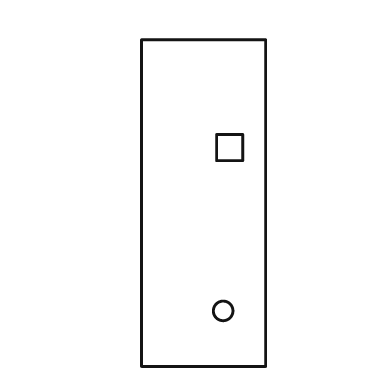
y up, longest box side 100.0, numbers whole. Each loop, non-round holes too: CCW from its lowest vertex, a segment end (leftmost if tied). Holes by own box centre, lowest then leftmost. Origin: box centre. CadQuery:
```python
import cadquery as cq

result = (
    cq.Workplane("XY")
    .moveTo(-19.0, -50.0)
    .lineTo(19.0, -50.0)
    .lineTo(19.0, 50.0)
    .lineTo(-19.0, 50.0)
    .close()
    .moveTo(6.0, -33.0)
    .circle(3.0)
    .moveTo(4.0, 13.0)
    .lineTo(12.0, 13.0)
    .lineTo(12.0, 21.0)
    .lineTo(4.0, 21.0)
    .close()
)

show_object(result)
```